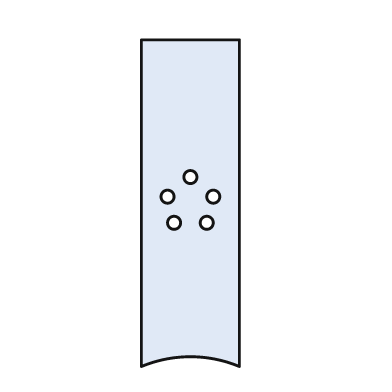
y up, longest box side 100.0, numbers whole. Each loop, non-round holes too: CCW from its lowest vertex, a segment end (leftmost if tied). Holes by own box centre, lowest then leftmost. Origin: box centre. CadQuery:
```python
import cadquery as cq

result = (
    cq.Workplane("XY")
    .moveTo(-15.0, -50.0)
    .threePointArc((0.0, -47.0), (15.0, -50.0))
    .lineTo(15.0, 50.0)
    .lineTo(-15.0, 50.0)
    .close()
    .moveTo(-5.0, -6.0)
    .circle(2.0)
    .moveTo(5.0, -6.0)
    .circle(2.0)
    .moveTo(-7.0, 2.0)
    .circle(2.0)
    .moveTo(7.0, 2.0)
    .circle(2.0)
    .moveTo(0.0, 8.0)
    .circle(2.0)
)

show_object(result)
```